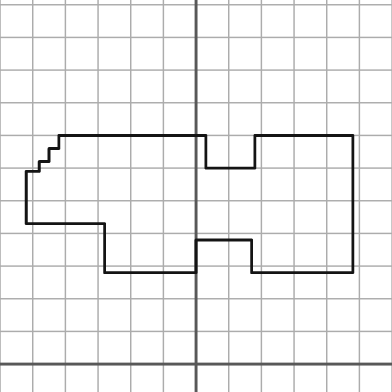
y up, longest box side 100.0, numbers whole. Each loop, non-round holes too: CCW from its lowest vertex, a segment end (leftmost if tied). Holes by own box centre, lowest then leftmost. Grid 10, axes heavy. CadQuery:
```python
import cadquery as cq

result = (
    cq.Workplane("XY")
    .moveTo(-28.0, 28.0)
    .lineTo(0.0, 28.0)
    .lineTo(0.0, 38.0)
    .lineTo(17.0, 38.0)
    .lineTo(17.0, 28.0)
    .lineTo(48.0, 28.0)
    .lineTo(48.0, 70.0)
    .lineTo(18.0, 70.0)
    .lineTo(18.0, 60.0)
    .lineTo(3.0, 60.0)
    .lineTo(3.0, 70.0)
    .lineTo(-42.0, 70.0)
    .lineTo(-42.0, 66.0)
    .lineTo(-45.0, 66.0)
    .lineTo(-45.0, 62.0)
    .lineTo(-48.0, 62.0)
    .lineTo(-48.0, 59.0)
    .lineTo(-52.0, 59.0)
    .lineTo(-52.0, 43.0)
    .lineTo(-28.0, 43.0)
    .close()
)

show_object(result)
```